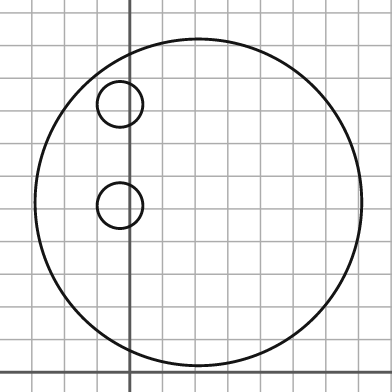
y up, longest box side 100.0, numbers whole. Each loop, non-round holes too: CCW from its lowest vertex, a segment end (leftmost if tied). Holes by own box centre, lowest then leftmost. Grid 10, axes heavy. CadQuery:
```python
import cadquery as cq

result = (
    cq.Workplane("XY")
    .moveTo(21.0, 52.0)
    .circle(50.0)
    .moveTo(-3.0, 51.0)
    .circle(7.0)
    .moveTo(-3.0, 82.0)
    .circle(7.0)
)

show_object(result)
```